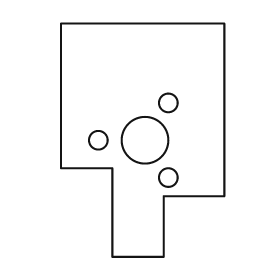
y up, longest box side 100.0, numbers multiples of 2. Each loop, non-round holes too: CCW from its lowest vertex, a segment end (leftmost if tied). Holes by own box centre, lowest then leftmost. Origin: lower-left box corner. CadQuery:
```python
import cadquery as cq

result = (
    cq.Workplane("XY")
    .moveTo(22.0, 0.0)
    .lineTo(44.0, 0.0)
    .lineTo(44.0, 26.0)
    .lineTo(70.0, 26.0)
    .lineTo(70.0, 100.0)
    .lineTo(0.0, 100.0)
    .lineTo(0.0, 38.0)
    .lineTo(22.0, 38.0)
    .close()
    .moveTo(46.0, 34.0)
    .circle(4.0)
    .moveTo(16.0, 50.0)
    .circle(4.0)
    .moveTo(36.0, 50.0)
    .circle(10.0)
    .moveTo(46.0, 66.0)
    .circle(4.0)
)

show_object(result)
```